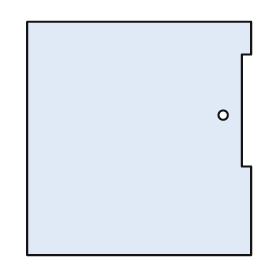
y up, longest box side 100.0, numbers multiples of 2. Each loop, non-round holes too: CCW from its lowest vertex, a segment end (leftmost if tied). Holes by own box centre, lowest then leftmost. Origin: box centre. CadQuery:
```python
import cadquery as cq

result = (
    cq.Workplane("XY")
    .moveTo(-48.0, -50.0)
    .lineTo(48.0, -50.0)
    .lineTo(48.0, -12.0)
    .lineTo(44.0, -12.0)
    .lineTo(44.0, 36.0)
    .lineTo(48.0, 36.0)
    .lineTo(48.0, 50.0)
    .lineTo(-48.0, 50.0)
    .close()
    .moveTo(36.0, 10.0)
    .circle(2.0)
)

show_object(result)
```